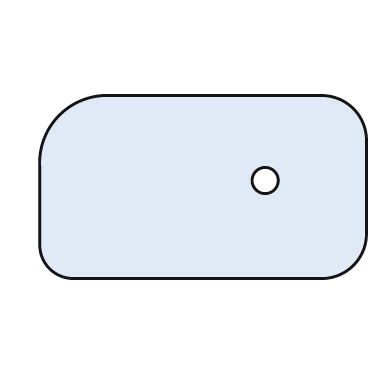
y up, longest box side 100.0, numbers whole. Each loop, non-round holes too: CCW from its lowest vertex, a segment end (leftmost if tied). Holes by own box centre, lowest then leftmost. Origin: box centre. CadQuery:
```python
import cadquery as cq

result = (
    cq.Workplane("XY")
    .moveTo(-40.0, -28.0)
    .lineTo(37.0, -28.0)
    .threePointArc((46.0, -24.0), (50.0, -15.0))
    .lineTo(50.0, 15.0)
    .threePointArc((46.0, 24.0), (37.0, 28.0))
    .lineTo(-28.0, 28.0)
    .threePointArc((-44.0, 22.0), (-50.0, 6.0))
    .lineTo(-50.0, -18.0)
    .threePointArc((-47.0, -25.0), (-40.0, -28.0))
    .close()
    .moveTo(19.0, 2.0)
    .circle(4.0)
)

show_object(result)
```